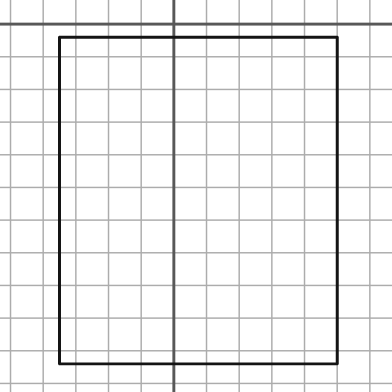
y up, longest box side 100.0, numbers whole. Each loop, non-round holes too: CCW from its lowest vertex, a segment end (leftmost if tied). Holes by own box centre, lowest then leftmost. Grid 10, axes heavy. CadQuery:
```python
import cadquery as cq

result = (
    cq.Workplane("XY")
    .moveTo(-35.0, -104.0)
    .lineTo(50.0, -104.0)
    .lineTo(50.0, -4.0)
    .lineTo(-35.0, -4.0)
    .close()
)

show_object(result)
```